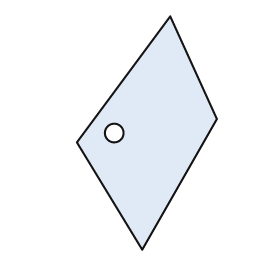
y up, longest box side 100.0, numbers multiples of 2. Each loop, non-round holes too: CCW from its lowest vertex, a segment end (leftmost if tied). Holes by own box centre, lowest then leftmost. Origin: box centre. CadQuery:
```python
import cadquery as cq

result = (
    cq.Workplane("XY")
    .moveTo(-2.0, -50.0)
    .lineTo(30.0, 6.0)
    .lineTo(10.0, 50.0)
    .lineTo(-30.0, -4.0)
    .close()
    .moveTo(-14.0, 0.0)
    .circle(4.0)
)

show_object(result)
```